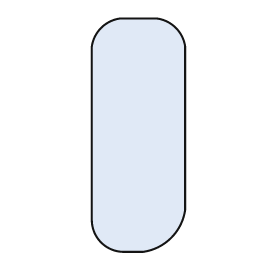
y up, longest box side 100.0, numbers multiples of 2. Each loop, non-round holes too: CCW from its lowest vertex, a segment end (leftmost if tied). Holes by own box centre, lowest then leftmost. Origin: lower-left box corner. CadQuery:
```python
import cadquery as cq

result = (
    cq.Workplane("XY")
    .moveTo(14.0, 0.0)
    .lineTo(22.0, 0.0)
    .threePointArc((34.0, 6.0), (40.0, 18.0))
    .lineTo(40.0, 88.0)
    .threePointArc((36.0, 96.0), (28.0, 100.0))
    .lineTo(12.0, 100.0)
    .threePointArc((4.0, 96.0), (0.0, 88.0))
    .lineTo(0.0, 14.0)
    .threePointArc((4.0, 4.0), (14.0, 0.0))
    .close()
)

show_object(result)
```